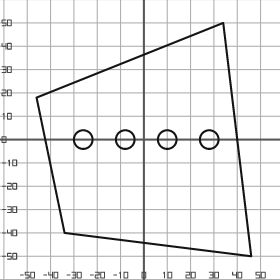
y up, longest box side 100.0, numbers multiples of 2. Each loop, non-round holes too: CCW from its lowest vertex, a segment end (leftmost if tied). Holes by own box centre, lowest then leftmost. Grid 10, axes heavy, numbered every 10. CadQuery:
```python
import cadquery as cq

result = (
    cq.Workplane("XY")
    .moveTo(46.0, -50.0)
    .lineTo(34.0, 50.0)
    .lineTo(-46.0, 18.0)
    .lineTo(-34.0, -40.0)
    .close()
    .moveTo(-26.0, 0.0)
    .circle(4.0)
    .moveTo(-8.0, 0.0)
    .circle(4.0)
    .moveTo(10.0, 0.0)
    .circle(4.0)
    .moveTo(28.0, 0.0)
    .circle(4.0)
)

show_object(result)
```